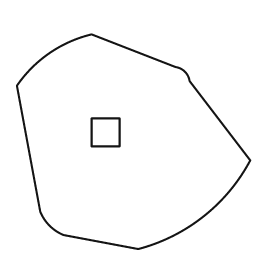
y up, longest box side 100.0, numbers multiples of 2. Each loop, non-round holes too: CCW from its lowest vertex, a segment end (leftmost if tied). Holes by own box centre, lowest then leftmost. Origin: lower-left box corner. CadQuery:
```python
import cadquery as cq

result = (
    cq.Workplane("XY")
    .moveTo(52.0, 0.0)
    .threePointArc((80.0, 14.0), (100.0, 38.0))
    .lineTo(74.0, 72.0)
    .threePointArc((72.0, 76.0), (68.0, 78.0))
    .lineTo(32.0, 92.0)
    .threePointArc((14.0, 84.0), (0.0, 70.0))
    .lineTo(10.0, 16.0)
    .threePointArc((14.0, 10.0), (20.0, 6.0))
    .close()
    .moveTo(32.0, 44.0)
    .lineTo(44.0, 44.0)
    .lineTo(44.0, 56.0)
    .lineTo(32.0, 56.0)
    .close()
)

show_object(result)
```